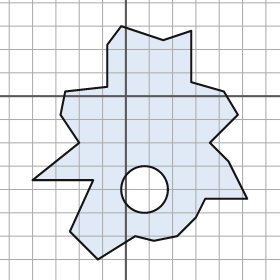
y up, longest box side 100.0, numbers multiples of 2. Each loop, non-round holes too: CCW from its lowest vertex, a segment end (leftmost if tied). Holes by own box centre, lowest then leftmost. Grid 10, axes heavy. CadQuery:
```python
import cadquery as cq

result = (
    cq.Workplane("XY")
    .moveTo(-12.0, -70.0)
    .lineTo(4.0, -60.0)
    .lineTo(12.0, -62.0)
    .lineTo(22.0, -60.0)
    .lineTo(30.0, -52.0)
    .lineTo(34.0, -44.0)
    .lineTo(52.0, -44.0)
    .lineTo(44.0, -28.0)
    .lineTo(36.0, -20.0)
    .lineTo(48.0, -8.0)
    .lineTo(42.0, 2.0)
    .lineTo(28.0, 6.0)
    .lineTo(28.0, 28.0)
    .lineTo(16.0, 24.0)
    .lineTo(-2.0, 30.0)
    .lineTo(-8.0, 22.0)
    .lineTo(-8.0, 4.0)
    .lineTo(-26.0, 2.0)
    .lineTo(-28.0, -8.0)
    .lineTo(-20.0, -20.0)
    .lineTo(-40.0, -36.0)
    .lineTo(-14.0, -36.0)
    .lineTo(-24.0, -58.0)
    .close()
    .moveTo(8.0, -40.0)
    .circle(10.0)
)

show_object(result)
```